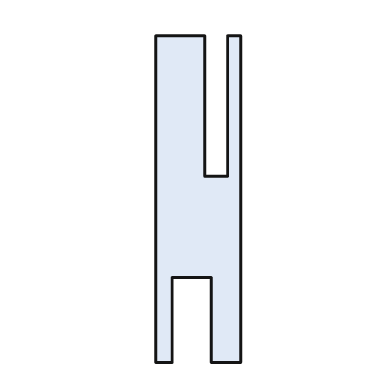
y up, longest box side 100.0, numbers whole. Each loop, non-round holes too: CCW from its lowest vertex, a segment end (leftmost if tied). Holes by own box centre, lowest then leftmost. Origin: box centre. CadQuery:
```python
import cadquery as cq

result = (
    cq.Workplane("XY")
    .moveTo(-13.0, -50.0)
    .lineTo(-8.0, -50.0)
    .lineTo(-8.0, -24.0)
    .lineTo(4.0, -24.0)
    .lineTo(4.0, -50.0)
    .lineTo(13.0, -50.0)
    .lineTo(13.0, 50.0)
    .lineTo(9.0, 50.0)
    .lineTo(9.0, 7.0)
    .lineTo(2.0, 7.0)
    .lineTo(2.0, 50.0)
    .lineTo(-13.0, 50.0)
    .close()
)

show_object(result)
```